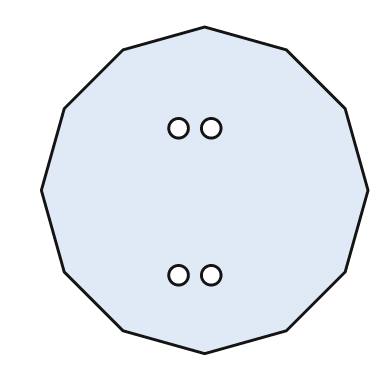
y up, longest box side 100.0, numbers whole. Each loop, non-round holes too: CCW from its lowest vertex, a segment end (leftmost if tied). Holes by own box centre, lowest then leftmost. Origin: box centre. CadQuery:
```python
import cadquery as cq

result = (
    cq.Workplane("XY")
    .moveTo(0.0, -50.0)
    .lineTo(25.0, -43.0)
    .lineTo(43.0, -25.0)
    .lineTo(50.0, 0.0)
    .lineTo(43.0, 25.0)
    .lineTo(25.0, 43.0)
    .lineTo(0.0, 50.0)
    .lineTo(-25.0, 43.0)
    .lineTo(-43.0, 25.0)
    .lineTo(-50.0, 0.0)
    .lineTo(-43.0, -25.0)
    .lineTo(-25.0, -43.0)
    .close()
    .moveTo(-8.0, -26.0)
    .circle(3.0)
    .moveTo(2.0, -26.0)
    .circle(3.0)
    .moveTo(-8.0, 19.0)
    .circle(3.0)
    .moveTo(2.0, 19.0)
    .circle(3.0)
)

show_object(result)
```